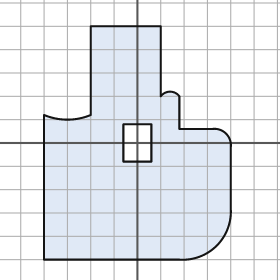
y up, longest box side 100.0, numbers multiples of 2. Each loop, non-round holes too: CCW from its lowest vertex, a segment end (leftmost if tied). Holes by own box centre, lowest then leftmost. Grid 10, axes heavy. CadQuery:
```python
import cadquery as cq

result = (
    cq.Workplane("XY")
    .moveTo(-40.0, -50.0)
    .lineTo(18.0, -50.0)
    .threePointArc((34.0, -44.0), (40.0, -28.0))
    .lineTo(40.0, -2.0)
    .threePointArc((38.0, 4.0), (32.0, 6.0))
    .lineTo(18.0, 6.0)
    .lineTo(18.0, 20.0)
    .threePointArc((14.0, 22.0), (10.0, 20.0))
    .lineTo(10.0, 50.0)
    .lineTo(-20.0, 50.0)
    .lineTo(-20.0, 12.0)
    .threePointArc((-30.0, 10.0), (-40.0, 12.0))
    .close()
    .moveTo(-6.0, -8.0)
    .lineTo(6.0, -8.0)
    .lineTo(6.0, 8.0)
    .lineTo(-6.0, 8.0)
    .close()
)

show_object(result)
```